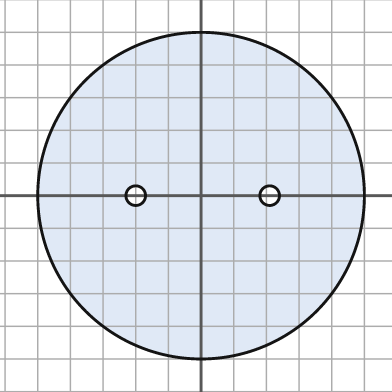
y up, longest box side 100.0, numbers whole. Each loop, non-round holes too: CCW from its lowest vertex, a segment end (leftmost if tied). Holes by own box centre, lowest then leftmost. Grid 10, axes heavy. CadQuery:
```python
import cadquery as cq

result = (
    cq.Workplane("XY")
    .moveTo(0.0, 0.0)
    .circle(50.0)
    .moveTo(-20.0, 0.0)
    .circle(3.0)
    .moveTo(21.0, 0.0)
    .circle(3.0)
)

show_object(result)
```